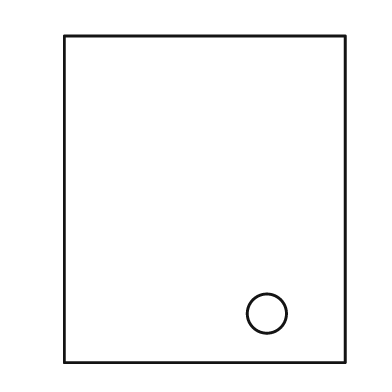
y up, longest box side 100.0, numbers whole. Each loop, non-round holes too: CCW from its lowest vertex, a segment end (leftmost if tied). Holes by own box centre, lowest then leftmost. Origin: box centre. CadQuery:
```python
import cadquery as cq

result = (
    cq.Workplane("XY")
    .moveTo(-43.0, -50.0)
    .lineTo(43.0, -50.0)
    .lineTo(43.0, 50.0)
    .lineTo(-43.0, 50.0)
    .close()
    .moveTo(19.0, -35.0)
    .circle(6.0)
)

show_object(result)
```